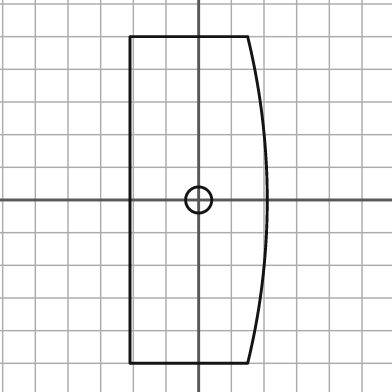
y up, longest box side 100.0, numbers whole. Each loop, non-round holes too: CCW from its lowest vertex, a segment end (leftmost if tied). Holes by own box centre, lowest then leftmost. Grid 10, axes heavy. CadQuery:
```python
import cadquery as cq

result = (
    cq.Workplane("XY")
    .moveTo(-21.0, -50.0)
    .lineTo(15.0, -50.0)
    .threePointArc((21.0, 0.0), (15.0, 50.0))
    .lineTo(-21.0, 50.0)
    .close()
    .moveTo(0.0, 0.0)
    .circle(4.0)
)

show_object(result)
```